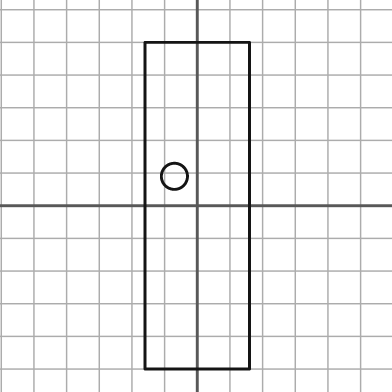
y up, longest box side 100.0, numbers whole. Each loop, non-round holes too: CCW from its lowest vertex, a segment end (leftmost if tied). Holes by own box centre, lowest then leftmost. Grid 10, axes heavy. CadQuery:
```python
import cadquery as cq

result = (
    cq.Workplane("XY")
    .moveTo(-16.0, -50.0)
    .lineTo(16.0, -50.0)
    .lineTo(16.0, 50.0)
    .lineTo(-16.0, 50.0)
    .close()
    .moveTo(-7.0, 9.0)
    .circle(4.0)
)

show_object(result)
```